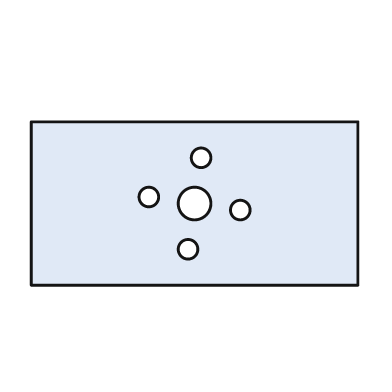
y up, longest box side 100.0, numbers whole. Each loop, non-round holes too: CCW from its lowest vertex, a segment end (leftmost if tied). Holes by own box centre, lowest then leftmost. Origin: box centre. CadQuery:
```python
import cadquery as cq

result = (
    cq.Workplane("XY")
    .moveTo(-50.0, -25.0)
    .lineTo(50.0, -25.0)
    .lineTo(50.0, 25.0)
    .lineTo(-50.0, 25.0)
    .close()
    .moveTo(-2.0, -14.0)
    .circle(3.0)
    .moveTo(14.0, -2.0)
    .circle(3.0)
    .moveTo(0.0, 0.0)
    .circle(5.0)
    .moveTo(-14.0, 2.0)
    .circle(3.0)
    .moveTo(2.0, 14.0)
    .circle(3.0)
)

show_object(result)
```